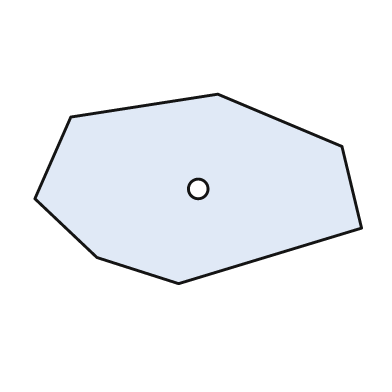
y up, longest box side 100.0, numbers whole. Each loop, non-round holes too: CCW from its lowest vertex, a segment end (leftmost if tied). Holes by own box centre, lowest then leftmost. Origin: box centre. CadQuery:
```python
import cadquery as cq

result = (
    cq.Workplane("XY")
    .moveTo(-6.0, -29.0)
    .lineTo(50.0, -12.0)
    .lineTo(44.0, 13.0)
    .lineTo(6.0, 29.0)
    .lineTo(-39.0, 22.0)
    .lineTo(-50.0, -3.0)
    .lineTo(-31.0, -21.0)
    .close()
    .moveTo(0.0, 0.0)
    .circle(3.0)
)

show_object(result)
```